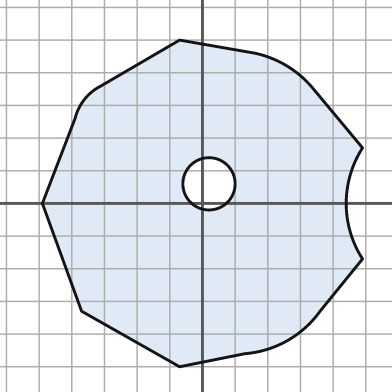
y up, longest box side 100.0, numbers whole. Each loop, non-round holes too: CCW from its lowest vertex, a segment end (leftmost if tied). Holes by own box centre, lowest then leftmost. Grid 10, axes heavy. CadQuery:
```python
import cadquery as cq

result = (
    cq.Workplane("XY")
    .moveTo(-7.0, -50.0)
    .lineTo(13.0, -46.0)
    .threePointArc((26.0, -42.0), (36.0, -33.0))
    .lineTo(49.0, -17.0)
    .threePointArc((44.0, 0.0), (49.0, 17.0))
    .lineTo(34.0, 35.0)
    .threePointArc((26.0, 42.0), (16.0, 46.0))
    .lineTo(-7.0, 50.0)
    .lineTo(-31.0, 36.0)
    .threePointArc((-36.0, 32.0), (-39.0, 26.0))
    .lineTo(-49.0, 0.0)
    .lineTo(-37.0, -33.0)
    .close()
    .moveTo(2.0, 6.0)
    .circle(8.0)
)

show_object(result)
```